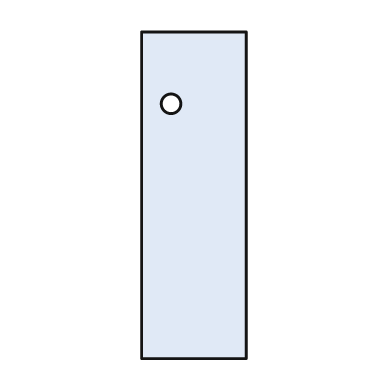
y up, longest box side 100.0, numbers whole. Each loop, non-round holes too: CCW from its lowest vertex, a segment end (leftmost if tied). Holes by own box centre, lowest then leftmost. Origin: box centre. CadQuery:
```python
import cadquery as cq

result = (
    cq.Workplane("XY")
    .moveTo(-16.0, -50.0)
    .lineTo(16.0, -50.0)
    .lineTo(16.0, 50.0)
    .lineTo(-16.0, 50.0)
    .close()
    .moveTo(-7.0, 28.0)
    .circle(3.0)
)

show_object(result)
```